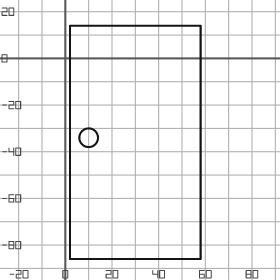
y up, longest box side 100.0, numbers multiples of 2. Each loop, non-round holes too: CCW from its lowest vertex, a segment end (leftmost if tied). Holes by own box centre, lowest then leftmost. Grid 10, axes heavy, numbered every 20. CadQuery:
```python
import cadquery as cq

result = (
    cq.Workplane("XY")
    .moveTo(2.0, -86.0)
    .lineTo(58.0, -86.0)
    .lineTo(58.0, 14.0)
    .lineTo(2.0, 14.0)
    .close()
    .moveTo(10.0, -34.0)
    .circle(4.0)
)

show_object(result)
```